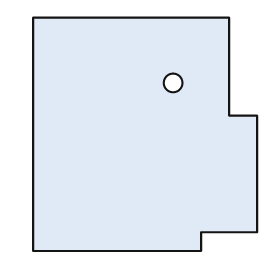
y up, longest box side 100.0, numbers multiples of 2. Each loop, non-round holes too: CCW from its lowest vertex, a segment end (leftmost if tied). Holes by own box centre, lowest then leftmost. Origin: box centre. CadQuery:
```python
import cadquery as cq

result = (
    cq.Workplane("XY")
    .moveTo(-48.0, -50.0)
    .lineTo(24.0, -50.0)
    .lineTo(24.0, -42.0)
    .lineTo(48.0, -42.0)
    .lineTo(48.0, 8.0)
    .lineTo(36.0, 8.0)
    .lineTo(36.0, 50.0)
    .lineTo(-48.0, 50.0)
    .close()
    .moveTo(12.0, 22.0)
    .circle(4.0)
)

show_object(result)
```